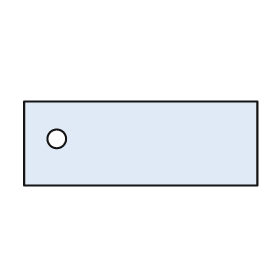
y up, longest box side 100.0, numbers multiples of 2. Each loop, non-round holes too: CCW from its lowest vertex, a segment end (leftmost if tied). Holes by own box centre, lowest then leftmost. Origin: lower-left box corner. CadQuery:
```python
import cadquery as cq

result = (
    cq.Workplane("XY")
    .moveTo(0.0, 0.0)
    .lineTo(100.0, 0.0)
    .lineTo(100.0, 36.0)
    .lineTo(0.0, 36.0)
    .close()
    .moveTo(14.0, 20.0)
    .circle(4.0)
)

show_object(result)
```